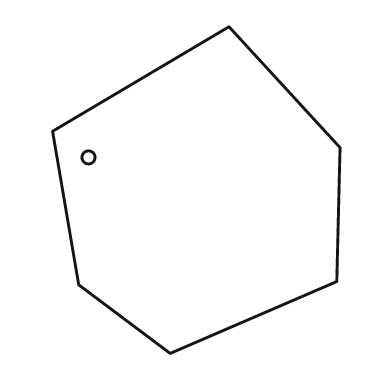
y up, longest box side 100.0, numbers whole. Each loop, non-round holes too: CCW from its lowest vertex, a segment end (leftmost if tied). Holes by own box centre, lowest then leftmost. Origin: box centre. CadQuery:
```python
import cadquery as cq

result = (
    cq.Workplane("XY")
    .moveTo(-8.0, -50.0)
    .lineTo(43.0, -28.0)
    .lineTo(44.0, 13.0)
    .lineTo(10.0, 50.0)
    .lineTo(-44.0, 18.0)
    .lineTo(-36.0, -29.0)
    .close()
    .moveTo(-33.0, 10.0)
    .circle(2.0)
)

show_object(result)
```